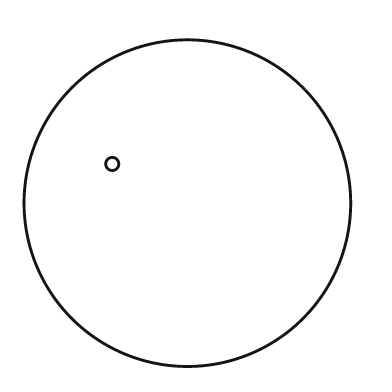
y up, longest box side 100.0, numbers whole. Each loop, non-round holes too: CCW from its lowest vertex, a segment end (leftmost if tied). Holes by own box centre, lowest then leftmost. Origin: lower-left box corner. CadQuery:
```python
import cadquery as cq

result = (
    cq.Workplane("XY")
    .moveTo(50.0, 50.0)
    .circle(50.0)
    .moveTo(27.0, 62.0)
    .circle(2.0)
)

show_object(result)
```